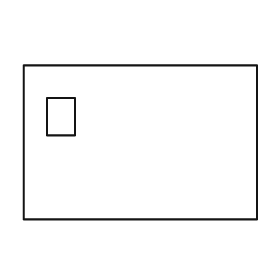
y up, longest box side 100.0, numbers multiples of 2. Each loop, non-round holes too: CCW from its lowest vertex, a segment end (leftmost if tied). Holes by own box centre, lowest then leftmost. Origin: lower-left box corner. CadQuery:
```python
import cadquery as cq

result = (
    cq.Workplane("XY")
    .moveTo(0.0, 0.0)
    .lineTo(100.0, 0.0)
    .lineTo(100.0, 66.0)
    .lineTo(0.0, 66.0)
    .close()
    .moveTo(10.0, 36.0)
    .lineTo(22.0, 36.0)
    .lineTo(22.0, 52.0)
    .lineTo(10.0, 52.0)
    .close()
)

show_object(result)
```